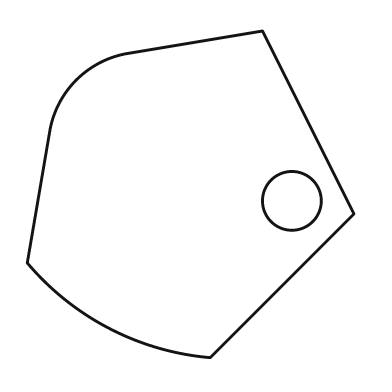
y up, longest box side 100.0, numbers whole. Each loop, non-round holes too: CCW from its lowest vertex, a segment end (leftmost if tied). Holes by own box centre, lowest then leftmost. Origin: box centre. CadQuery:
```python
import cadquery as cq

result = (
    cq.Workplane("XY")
    .moveTo(6.0, -50.0)
    .lineTo(50.0, -6.0)
    .lineTo(22.0, 50.0)
    .lineTo(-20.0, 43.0)
    .threePointArc((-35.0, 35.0), (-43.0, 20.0))
    .lineTo(-50.0, -21.0)
    .threePointArc((-25.0, -41.0), (6.0, -50.0))
    .close()
    .moveTo(31.0, -2.0)
    .circle(9.0)
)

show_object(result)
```